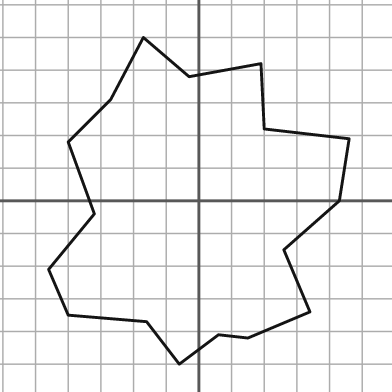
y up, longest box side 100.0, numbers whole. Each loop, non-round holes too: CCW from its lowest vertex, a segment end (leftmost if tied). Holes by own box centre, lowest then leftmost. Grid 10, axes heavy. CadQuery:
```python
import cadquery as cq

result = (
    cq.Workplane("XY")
    .moveTo(-6.0, -50.0)
    .lineTo(6.0, -41.0)
    .lineTo(15.0, -42.0)
    .lineTo(34.0, -34.0)
    .lineTo(26.0, -15.0)
    .lineTo(43.0, 0.0)
    .lineTo(46.0, 19.0)
    .lineTo(20.0, 22.0)
    .lineTo(19.0, 42.0)
    .lineTo(-3.0, 38.0)
    .lineTo(-17.0, 50.0)
    .lineTo(-27.0, 31.0)
    .lineTo(-40.0, 18.0)
    .lineTo(-32.0, -4.0)
    .lineTo(-46.0, -21.0)
    .lineTo(-40.0, -35.0)
    .lineTo(-16.0, -37.0)
    .close()
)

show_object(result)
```